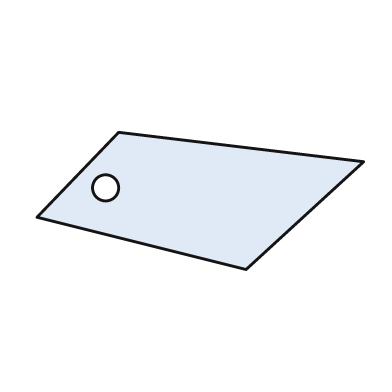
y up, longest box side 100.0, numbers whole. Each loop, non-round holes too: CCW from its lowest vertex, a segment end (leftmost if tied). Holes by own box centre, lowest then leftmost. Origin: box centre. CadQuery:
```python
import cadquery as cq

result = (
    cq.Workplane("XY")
    .moveTo(14.0, -21.0)
    .lineTo(50.0, 12.0)
    .lineTo(-25.0, 21.0)
    .lineTo(-50.0, -5.0)
    .close()
    .moveTo(-29.0, 4.0)
    .circle(4.0)
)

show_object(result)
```